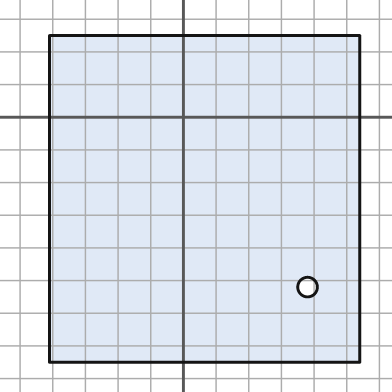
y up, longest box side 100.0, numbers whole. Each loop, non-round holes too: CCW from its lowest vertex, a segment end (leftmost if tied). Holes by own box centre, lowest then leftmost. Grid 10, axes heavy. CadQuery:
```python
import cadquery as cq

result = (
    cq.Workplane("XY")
    .moveTo(-41.0, -75.0)
    .lineTo(54.0, -75.0)
    .lineTo(54.0, 25.0)
    .lineTo(-41.0, 25.0)
    .close()
    .moveTo(38.0, -52.0)
    .circle(3.0)
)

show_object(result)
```